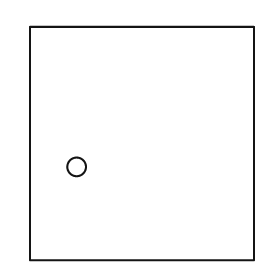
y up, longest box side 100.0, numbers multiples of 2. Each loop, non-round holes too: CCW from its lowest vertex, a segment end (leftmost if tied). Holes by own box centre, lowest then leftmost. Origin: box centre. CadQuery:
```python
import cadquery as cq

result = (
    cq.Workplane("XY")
    .moveTo(-48.0, -50.0)
    .lineTo(48.0, -50.0)
    .lineTo(48.0, 50.0)
    .lineTo(-48.0, 50.0)
    .close()
    .moveTo(-28.0, -10.0)
    .circle(4.0)
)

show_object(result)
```